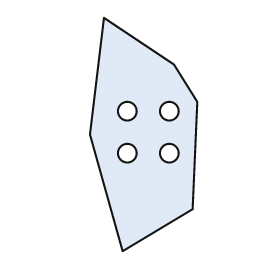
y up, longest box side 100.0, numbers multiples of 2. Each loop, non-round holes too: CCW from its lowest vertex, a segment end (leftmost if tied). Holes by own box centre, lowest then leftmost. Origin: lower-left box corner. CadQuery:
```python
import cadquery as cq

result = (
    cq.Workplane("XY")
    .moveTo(14.0, 0.0)
    .lineTo(44.0, 18.0)
    .lineTo(46.0, 64.0)
    .lineTo(36.0, 80.0)
    .lineTo(6.0, 100.0)
    .lineTo(0.0, 50.0)
    .close()
    .moveTo(16.0, 42.0)
    .circle(4.0)
    .moveTo(34.0, 42.0)
    .circle(4.0)
    .moveTo(16.0, 60.0)
    .circle(4.0)
    .moveTo(34.0, 60.0)
    .circle(4.0)
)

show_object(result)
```